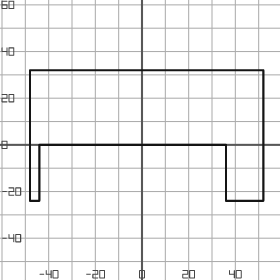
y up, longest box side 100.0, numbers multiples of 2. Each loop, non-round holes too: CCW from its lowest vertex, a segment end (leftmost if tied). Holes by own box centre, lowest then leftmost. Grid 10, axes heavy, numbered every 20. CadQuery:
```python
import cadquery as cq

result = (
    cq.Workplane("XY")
    .moveTo(-48.0, -24.0)
    .lineTo(-44.0, -24.0)
    .lineTo(-44.0, 0.0)
    .lineTo(36.0, 0.0)
    .lineTo(36.0, -24.0)
    .lineTo(52.0, -24.0)
    .lineTo(52.0, 32.0)
    .lineTo(-48.0, 32.0)
    .close()
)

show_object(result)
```